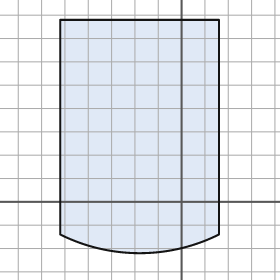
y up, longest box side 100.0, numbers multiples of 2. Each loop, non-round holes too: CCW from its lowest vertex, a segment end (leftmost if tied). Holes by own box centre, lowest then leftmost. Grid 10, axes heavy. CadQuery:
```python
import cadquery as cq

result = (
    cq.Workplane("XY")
    .moveTo(-52.0, -14.0)
    .threePointArc((-18.0, -22.0), (16.0, -14.0))
    .lineTo(16.0, 78.0)
    .lineTo(-52.0, 78.0)
    .close()
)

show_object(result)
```